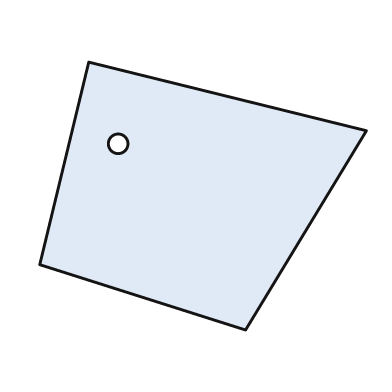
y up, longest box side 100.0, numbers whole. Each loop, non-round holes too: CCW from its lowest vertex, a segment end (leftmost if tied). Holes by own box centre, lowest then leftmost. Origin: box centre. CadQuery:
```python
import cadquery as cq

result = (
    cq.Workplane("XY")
    .moveTo(13.0, -41.0)
    .lineTo(50.0, 20.0)
    .lineTo(-35.0, 41.0)
    .lineTo(-50.0, -21.0)
    .close()
    .moveTo(-26.0, 16.0)
    .circle(3.0)
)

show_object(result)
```